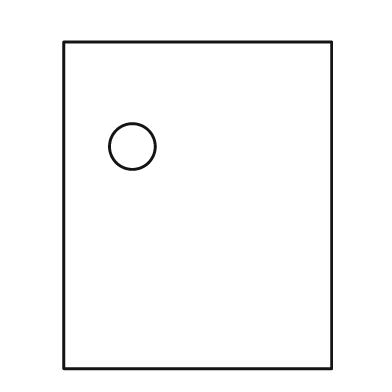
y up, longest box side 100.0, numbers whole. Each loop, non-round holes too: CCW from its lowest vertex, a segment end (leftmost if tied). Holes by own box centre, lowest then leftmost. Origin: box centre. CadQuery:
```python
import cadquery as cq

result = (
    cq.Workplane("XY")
    .moveTo(-41.0, -50.0)
    .lineTo(41.0, -50.0)
    .lineTo(41.0, 50.0)
    .lineTo(-41.0, 50.0)
    .close()
    .moveTo(-20.0, 18.0)
    .circle(7.0)
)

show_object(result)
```